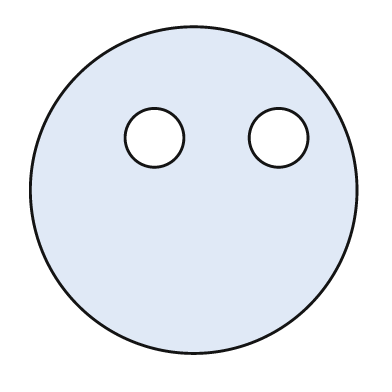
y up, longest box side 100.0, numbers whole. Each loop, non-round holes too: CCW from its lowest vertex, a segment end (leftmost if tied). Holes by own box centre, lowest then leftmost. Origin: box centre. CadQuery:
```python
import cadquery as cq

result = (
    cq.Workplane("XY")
    .moveTo(0.0, 0.0)
    .circle(50.0)
    .moveTo(-12.0, 16.0)
    .circle(9.0)
    .moveTo(26.0, 16.0)
    .circle(9.0)
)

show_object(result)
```